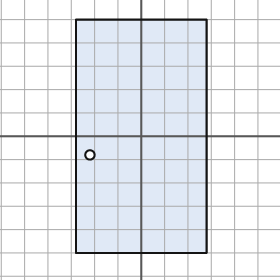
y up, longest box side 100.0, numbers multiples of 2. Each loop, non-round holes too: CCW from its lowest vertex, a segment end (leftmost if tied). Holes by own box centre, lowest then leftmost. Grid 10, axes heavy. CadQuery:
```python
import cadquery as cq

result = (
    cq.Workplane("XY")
    .moveTo(-28.0, -50.0)
    .lineTo(28.0, -50.0)
    .lineTo(28.0, 50.0)
    .lineTo(-28.0, 50.0)
    .close()
    .moveTo(-22.0, -8.0)
    .circle(2.0)
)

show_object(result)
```